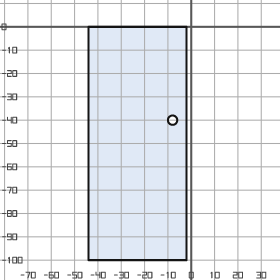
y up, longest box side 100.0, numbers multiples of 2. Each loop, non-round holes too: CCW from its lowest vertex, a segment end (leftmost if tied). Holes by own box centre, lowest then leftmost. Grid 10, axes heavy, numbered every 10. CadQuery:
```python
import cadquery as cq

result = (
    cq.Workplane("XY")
    .moveTo(-44.0, -100.0)
    .lineTo(-2.0, -100.0)
    .lineTo(-2.0, 0.0)
    .lineTo(-44.0, 0.0)
    .close()
    .moveTo(-8.0, -40.0)
    .circle(2.0)
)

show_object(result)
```